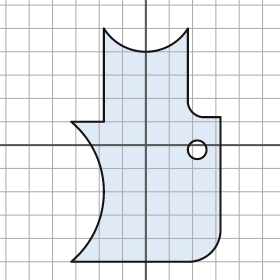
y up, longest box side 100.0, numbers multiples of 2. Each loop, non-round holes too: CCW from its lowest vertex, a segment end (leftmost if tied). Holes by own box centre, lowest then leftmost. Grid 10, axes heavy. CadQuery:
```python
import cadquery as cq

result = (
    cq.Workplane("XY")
    .moveTo(-32.0, -50.0)
    .lineTo(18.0, -50.0)
    .threePointArc((28.0, -46.0), (32.0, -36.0))
    .lineTo(32.0, 12.0)
    .lineTo(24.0, 12.0)
    .threePointArc((20.0, 14.0), (18.0, 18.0))
    .lineTo(18.0, 50.0)
    .threePointArc((0.0, 40.0), (-18.0, 50.0))
    .lineTo(-18.0, 10.0)
    .lineTo(-32.0, 10.0)
    .threePointArc((-18.0, -20.0), (-32.0, -50.0))
    .close()
    .moveTo(22.0, -2.0)
    .circle(4.0)
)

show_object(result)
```